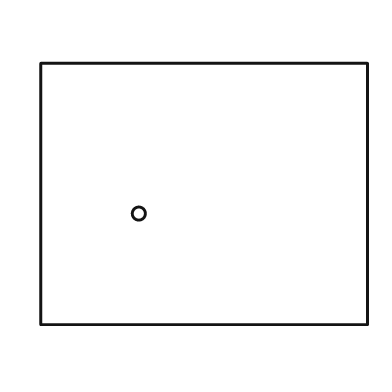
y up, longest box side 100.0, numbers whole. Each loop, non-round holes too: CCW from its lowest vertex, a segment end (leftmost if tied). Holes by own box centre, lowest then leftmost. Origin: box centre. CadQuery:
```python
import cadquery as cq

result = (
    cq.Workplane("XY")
    .moveTo(-50.0, -40.0)
    .lineTo(50.0, -40.0)
    .lineTo(50.0, 40.0)
    .lineTo(-50.0, 40.0)
    .close()
    .moveTo(-20.0, -6.0)
    .circle(2.0)
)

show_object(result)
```